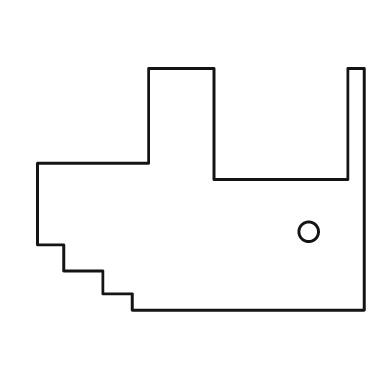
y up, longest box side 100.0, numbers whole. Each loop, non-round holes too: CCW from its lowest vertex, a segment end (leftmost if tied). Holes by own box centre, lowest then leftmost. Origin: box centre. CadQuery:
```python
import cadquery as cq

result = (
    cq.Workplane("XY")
    .moveTo(-21.0, -37.0)
    .lineTo(50.0, -37.0)
    .lineTo(50.0, 37.0)
    .lineTo(45.0, 37.0)
    .lineTo(45.0, 3.0)
    .lineTo(4.0, 3.0)
    .lineTo(4.0, 37.0)
    .lineTo(-16.0, 37.0)
    .lineTo(-16.0, 8.0)
    .lineTo(-50.0, 8.0)
    .lineTo(-50.0, -17.0)
    .lineTo(-42.0, -17.0)
    .lineTo(-42.0, -25.0)
    .lineTo(-30.0, -25.0)
    .lineTo(-30.0, -32.0)
    .lineTo(-21.0, -32.0)
    .close()
    .moveTo(33.0, -13.0)
    .circle(3.0)
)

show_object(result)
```